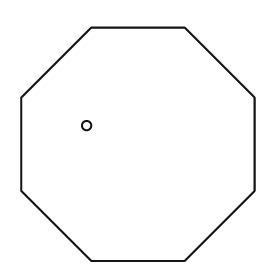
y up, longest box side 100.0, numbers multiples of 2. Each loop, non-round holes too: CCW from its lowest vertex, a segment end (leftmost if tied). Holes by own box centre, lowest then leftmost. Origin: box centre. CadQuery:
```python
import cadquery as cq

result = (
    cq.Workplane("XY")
    .moveTo(-20.0, -50.0)
    .lineTo(20.0, -50.0)
    .lineTo(50.0, -20.0)
    .lineTo(50.0, 20.0)
    .lineTo(20.0, 50.0)
    .lineTo(-20.0, 50.0)
    .lineTo(-50.0, 20.0)
    .lineTo(-50.0, -20.0)
    .close()
    .moveTo(-22.0, 8.0)
    .circle(2.0)
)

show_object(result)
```